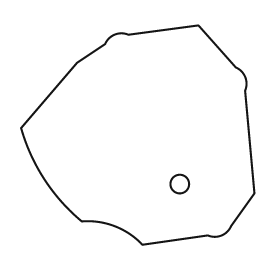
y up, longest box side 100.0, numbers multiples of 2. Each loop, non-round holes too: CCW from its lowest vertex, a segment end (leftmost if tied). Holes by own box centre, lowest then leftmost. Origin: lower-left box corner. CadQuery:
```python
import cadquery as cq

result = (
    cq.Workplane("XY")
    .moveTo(52.0, 0.0)
    .lineTo(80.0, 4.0)
    .threePointArc((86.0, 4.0), (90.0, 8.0))
    .lineTo(100.0, 22.0)
    .lineTo(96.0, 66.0)
    .threePointArc((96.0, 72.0), (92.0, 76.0))
    .lineTo(76.0, 94.0)
    .lineTo(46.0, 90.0)
    .threePointArc((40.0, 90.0), (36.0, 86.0))
    .lineTo(24.0, 78.0)
    .lineTo(0.0, 50.0)
    .threePointArc((10.0, 28.0), (26.0, 10.0))
    .threePointArc((40.0, 8.0), (52.0, 0.0))
    .close()
    .moveTo(68.0, 26.0)
    .circle(4.0)
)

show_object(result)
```